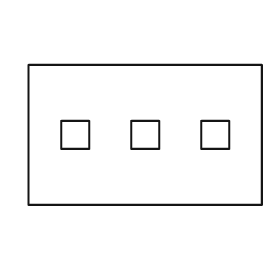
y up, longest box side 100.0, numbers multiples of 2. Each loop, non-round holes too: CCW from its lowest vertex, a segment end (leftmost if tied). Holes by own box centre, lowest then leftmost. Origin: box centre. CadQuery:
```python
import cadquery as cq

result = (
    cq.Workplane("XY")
    .moveTo(-50.0, -30.0)
    .lineTo(50.0, -30.0)
    .lineTo(50.0, 30.0)
    .lineTo(-50.0, 30.0)
    .close()
    .moveTo(-36.0, -6.0)
    .lineTo(-24.0, -6.0)
    .lineTo(-24.0, 6.0)
    .lineTo(-36.0, 6.0)
    .close()
    .moveTo(-6.0, -6.0)
    .lineTo(6.0, -6.0)
    .lineTo(6.0, 6.0)
    .lineTo(-6.0, 6.0)
    .close()
    .moveTo(24.0, -6.0)
    .lineTo(36.0, -6.0)
    .lineTo(36.0, 6.0)
    .lineTo(24.0, 6.0)
    .close()
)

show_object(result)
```